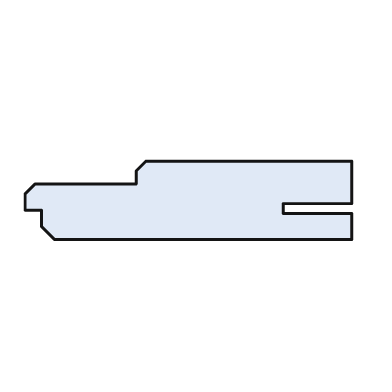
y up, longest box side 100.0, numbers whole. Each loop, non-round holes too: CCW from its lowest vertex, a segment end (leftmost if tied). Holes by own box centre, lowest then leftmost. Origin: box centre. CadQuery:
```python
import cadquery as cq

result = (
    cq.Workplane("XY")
    .moveTo(-41.0, -12.0)
    .lineTo(50.0, -12.0)
    .lineTo(50.0, -4.0)
    .lineTo(29.0, -4.0)
    .lineTo(29.0, -1.0)
    .lineTo(50.0, -1.0)
    .lineTo(50.0, 12.0)
    .lineTo(-13.0, 12.0)
    .lineTo(-16.0, 9.0)
    .lineTo(-16.0, 5.0)
    .lineTo(-47.0, 5.0)
    .lineTo(-50.0, 2.0)
    .lineTo(-50.0, -3.0)
    .lineTo(-45.0, -3.0)
    .lineTo(-45.0, -8.0)
    .close()
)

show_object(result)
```